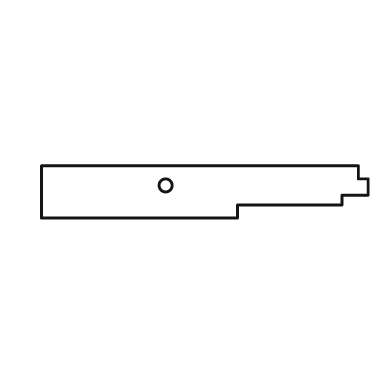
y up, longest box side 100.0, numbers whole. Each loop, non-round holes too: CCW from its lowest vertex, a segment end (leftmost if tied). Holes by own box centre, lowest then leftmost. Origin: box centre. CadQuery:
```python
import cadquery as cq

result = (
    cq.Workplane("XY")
    .moveTo(-50.0, -8.0)
    .lineTo(10.0, -8.0)
    .lineTo(10.0, -4.0)
    .lineTo(42.0, -4.0)
    .lineTo(42.0, -1.0)
    .lineTo(50.0, -1.0)
    .lineTo(50.0, 4.0)
    .lineTo(47.0, 4.0)
    .lineTo(47.0, 8.0)
    .lineTo(-50.0, 8.0)
    .close()
    .moveTo(-12.0, 2.0)
    .circle(2.0)
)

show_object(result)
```